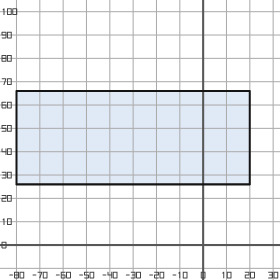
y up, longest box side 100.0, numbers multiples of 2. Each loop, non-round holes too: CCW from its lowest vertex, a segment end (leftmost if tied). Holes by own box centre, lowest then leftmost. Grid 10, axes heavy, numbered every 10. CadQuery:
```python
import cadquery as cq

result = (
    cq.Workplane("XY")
    .moveTo(-80.0, 26.0)
    .lineTo(20.0, 26.0)
    .lineTo(20.0, 66.0)
    .lineTo(-80.0, 66.0)
    .close()
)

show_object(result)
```